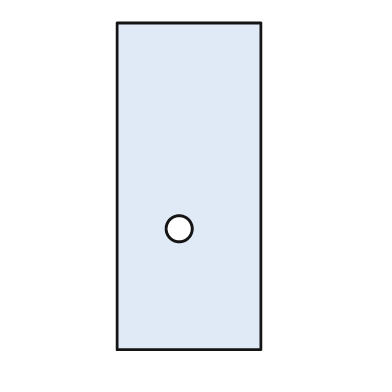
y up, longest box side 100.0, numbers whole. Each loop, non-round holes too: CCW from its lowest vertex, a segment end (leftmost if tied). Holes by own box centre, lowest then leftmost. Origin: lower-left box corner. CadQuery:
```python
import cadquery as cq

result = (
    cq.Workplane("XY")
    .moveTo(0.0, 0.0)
    .lineTo(44.0, 0.0)
    .lineTo(44.0, 100.0)
    .lineTo(0.0, 100.0)
    .close()
    .moveTo(19.0, 37.0)
    .circle(4.0)
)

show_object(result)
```